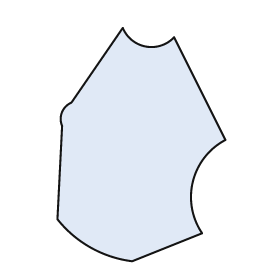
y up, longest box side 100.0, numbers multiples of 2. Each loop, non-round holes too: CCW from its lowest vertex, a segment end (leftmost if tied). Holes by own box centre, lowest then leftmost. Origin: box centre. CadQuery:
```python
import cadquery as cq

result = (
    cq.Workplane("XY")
    .moveTo(-4.0, -50.0)
    .lineTo(26.0, -38.0)
    .threePointArc((22.0, -16.0), (36.0, 2.0))
    .lineTo(14.0, 46.0)
    .threePointArc((2.0, 42.0), (-8.0, 50.0))
    .lineTo(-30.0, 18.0)
    .threePointArc((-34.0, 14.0), (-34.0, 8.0))
    .lineTo(-36.0, -32.0)
    .threePointArc((-22.0, -44.0), (-4.0, -50.0))
    .close()
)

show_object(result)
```